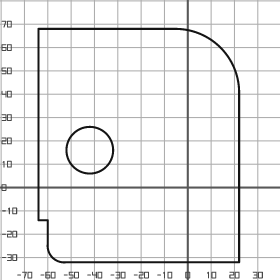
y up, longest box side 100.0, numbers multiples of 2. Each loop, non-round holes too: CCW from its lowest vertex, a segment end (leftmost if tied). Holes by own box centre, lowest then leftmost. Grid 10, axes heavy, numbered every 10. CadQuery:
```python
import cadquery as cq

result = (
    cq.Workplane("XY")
    .moveTo(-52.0, -32.0)
    .lineTo(22.0, -32.0)
    .lineTo(22.0, 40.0)
    .threePointArc((14.0, 60.0), (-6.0, 68.0))
    .lineTo(-64.0, 68.0)
    .lineTo(-64.0, -14.0)
    .lineTo(-60.0, -14.0)
    .lineTo(-60.0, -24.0)
    .threePointArc((-58.0, -30.0), (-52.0, -32.0))
    .close()
    .moveTo(-42.0, 16.0)
    .circle(10.0)
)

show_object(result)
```